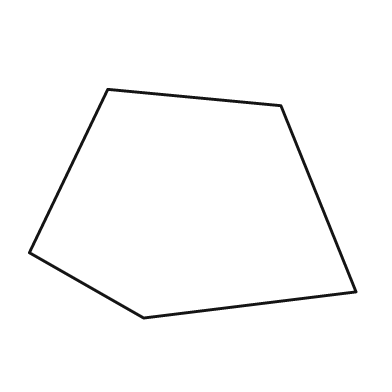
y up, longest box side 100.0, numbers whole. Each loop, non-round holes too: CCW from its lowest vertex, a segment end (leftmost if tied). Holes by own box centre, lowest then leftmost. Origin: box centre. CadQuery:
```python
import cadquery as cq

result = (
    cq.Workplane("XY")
    .moveTo(-15.0, -35.0)
    .lineTo(50.0, -27.0)
    .lineTo(27.0, 30.0)
    .lineTo(-26.0, 35.0)
    .lineTo(-50.0, -15.0)
    .close()
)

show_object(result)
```